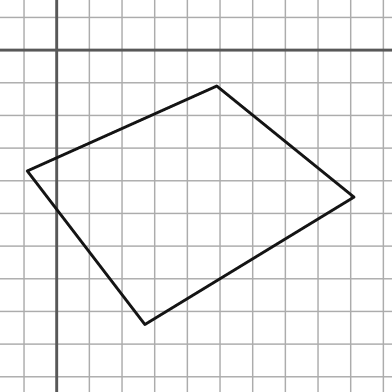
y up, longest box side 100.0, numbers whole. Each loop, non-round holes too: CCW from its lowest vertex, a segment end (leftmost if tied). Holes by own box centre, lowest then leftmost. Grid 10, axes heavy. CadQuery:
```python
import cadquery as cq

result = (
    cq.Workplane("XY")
    .moveTo(27.0, -84.0)
    .lineTo(91.0, -45.0)
    .lineTo(49.0, -11.0)
    .lineTo(-9.0, -37.0)
    .close()
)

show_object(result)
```